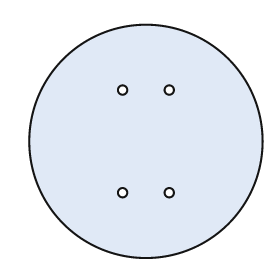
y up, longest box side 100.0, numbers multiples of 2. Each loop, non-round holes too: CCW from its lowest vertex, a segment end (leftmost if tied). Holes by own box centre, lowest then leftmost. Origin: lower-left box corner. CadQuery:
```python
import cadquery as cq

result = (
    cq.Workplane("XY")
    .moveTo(50.0, 50.0)
    .circle(50.0)
    .moveTo(40.0, 28.0)
    .circle(2.0)
    .moveTo(60.0, 28.0)
    .circle(2.0)
    .moveTo(40.0, 72.0)
    .circle(2.0)
    .moveTo(60.0, 72.0)
    .circle(2.0)
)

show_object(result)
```